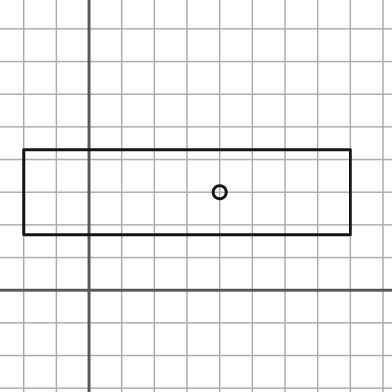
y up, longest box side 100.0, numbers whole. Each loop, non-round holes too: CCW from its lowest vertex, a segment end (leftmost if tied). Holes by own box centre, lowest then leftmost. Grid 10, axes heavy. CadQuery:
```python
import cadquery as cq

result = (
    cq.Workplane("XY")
    .moveTo(-20.0, 17.0)
    .lineTo(80.0, 17.0)
    .lineTo(80.0, 43.0)
    .lineTo(-20.0, 43.0)
    .close()
    .moveTo(40.0, 30.0)
    .circle(2.0)
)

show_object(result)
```